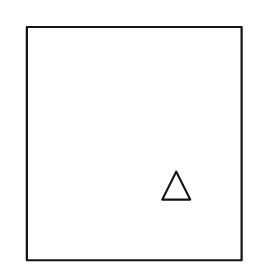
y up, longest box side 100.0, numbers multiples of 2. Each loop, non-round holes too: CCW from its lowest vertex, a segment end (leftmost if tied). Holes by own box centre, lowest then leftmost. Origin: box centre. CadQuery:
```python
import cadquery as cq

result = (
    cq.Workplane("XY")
    .moveTo(-46.0, -50.0)
    .lineTo(46.0, -50.0)
    .lineTo(46.0, 50.0)
    .lineTo(-46.0, 50.0)
    .close()
    .moveTo(12.0, -24.0)
    .lineTo(24.0, -24.0)
    .lineTo(18.0, -12.0)
    .close()
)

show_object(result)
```